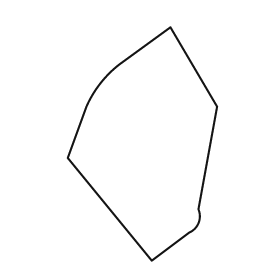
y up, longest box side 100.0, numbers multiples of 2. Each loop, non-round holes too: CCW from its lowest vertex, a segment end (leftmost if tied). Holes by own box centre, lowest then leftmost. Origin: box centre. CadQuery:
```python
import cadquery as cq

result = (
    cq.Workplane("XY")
    .moveTo(4.0, -50.0)
    .lineTo(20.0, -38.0)
    .threePointArc((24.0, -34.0), (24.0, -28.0))
    .lineTo(32.0, 16.0)
    .lineTo(12.0, 50.0)
    .lineTo(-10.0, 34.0)
    .threePointArc((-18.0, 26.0), (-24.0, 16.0))
    .lineTo(-32.0, -6.0)
    .close()
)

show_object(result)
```